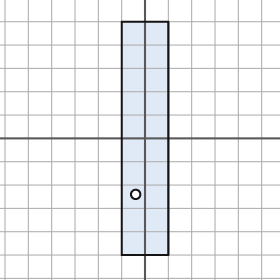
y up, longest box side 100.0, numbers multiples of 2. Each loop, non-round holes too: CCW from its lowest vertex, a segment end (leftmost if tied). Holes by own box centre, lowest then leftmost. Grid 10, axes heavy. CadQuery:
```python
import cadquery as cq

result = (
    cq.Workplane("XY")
    .moveTo(-10.0, -50.0)
    .lineTo(10.0, -50.0)
    .lineTo(10.0, 50.0)
    .lineTo(-10.0, 50.0)
    .close()
    .moveTo(-4.0, -24.0)
    .circle(2.0)
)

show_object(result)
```